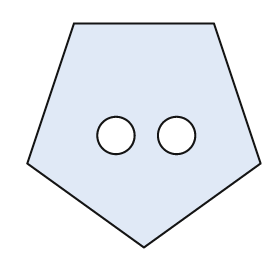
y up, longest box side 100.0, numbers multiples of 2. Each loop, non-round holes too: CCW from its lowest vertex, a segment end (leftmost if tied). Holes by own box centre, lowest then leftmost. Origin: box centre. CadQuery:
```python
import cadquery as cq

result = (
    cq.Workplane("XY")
    .moveTo(0.0, -48.0)
    .lineTo(50.0, -12.0)
    .lineTo(30.0, 48.0)
    .lineTo(-30.0, 48.0)
    .lineTo(-50.0, -12.0)
    .close()
    .moveTo(-12.0, 0.0)
    .circle(8.0)
    .moveTo(14.0, 0.0)
    .circle(8.0)
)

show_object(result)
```